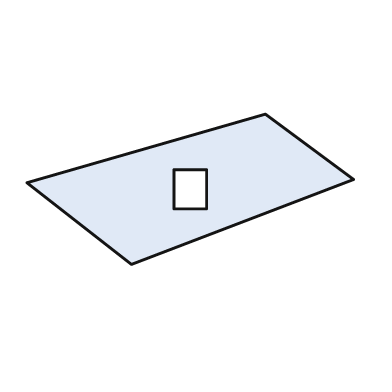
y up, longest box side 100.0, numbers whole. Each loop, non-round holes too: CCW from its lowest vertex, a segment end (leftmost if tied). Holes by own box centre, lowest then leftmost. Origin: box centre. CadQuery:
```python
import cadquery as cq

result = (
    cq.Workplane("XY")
    .moveTo(-18.0, -23.0)
    .lineTo(50.0, 3.0)
    .lineTo(23.0, 23.0)
    .lineTo(-50.0, 2.0)
    .close()
    .moveTo(-5.0, -6.0)
    .lineTo(5.0, -6.0)
    .lineTo(5.0, 6.0)
    .lineTo(-5.0, 6.0)
    .close()
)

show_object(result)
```